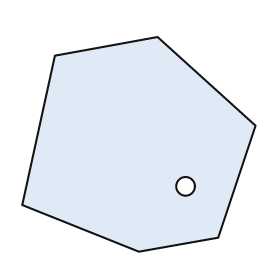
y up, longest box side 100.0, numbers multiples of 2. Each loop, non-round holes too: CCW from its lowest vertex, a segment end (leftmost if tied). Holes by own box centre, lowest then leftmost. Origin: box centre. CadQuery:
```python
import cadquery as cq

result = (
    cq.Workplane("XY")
    .moveTo(0.0, -46.0)
    .lineTo(34.0, -40.0)
    .lineTo(50.0, 8.0)
    .lineTo(8.0, 46.0)
    .lineTo(-36.0, 38.0)
    .lineTo(-50.0, -26.0)
    .close()
    .moveTo(20.0, -18.0)
    .circle(4.0)
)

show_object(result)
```